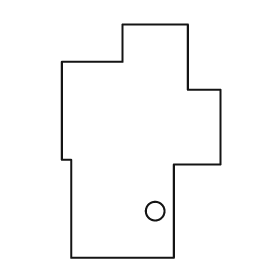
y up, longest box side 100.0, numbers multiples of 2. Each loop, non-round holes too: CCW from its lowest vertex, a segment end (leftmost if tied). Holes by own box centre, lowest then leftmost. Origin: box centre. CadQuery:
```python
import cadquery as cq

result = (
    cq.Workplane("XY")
    .moveTo(-30.0, -50.0)
    .lineTo(14.0, -50.0)
    .lineTo(14.0, -10.0)
    .lineTo(34.0, -10.0)
    .lineTo(34.0, 22.0)
    .lineTo(20.0, 22.0)
    .lineTo(20.0, 50.0)
    .lineTo(-8.0, 50.0)
    .lineTo(-8.0, 34.0)
    .lineTo(-34.0, 34.0)
    .lineTo(-34.0, -8.0)
    .lineTo(-30.0, -8.0)
    .close()
    .moveTo(6.0, -30.0)
    .circle(4.0)
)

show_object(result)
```